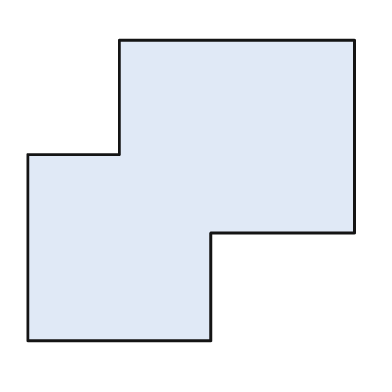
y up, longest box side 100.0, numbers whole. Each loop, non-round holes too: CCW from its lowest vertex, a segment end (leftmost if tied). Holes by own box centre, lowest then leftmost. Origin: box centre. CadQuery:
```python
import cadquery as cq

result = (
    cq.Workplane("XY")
    .moveTo(-50.0, -46.0)
    .lineTo(6.0, -46.0)
    .lineTo(6.0, -13.0)
    .lineTo(50.0, -13.0)
    .lineTo(50.0, 46.0)
    .lineTo(-22.0, 46.0)
    .lineTo(-22.0, 11.0)
    .lineTo(-50.0, 11.0)
    .close()
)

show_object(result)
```